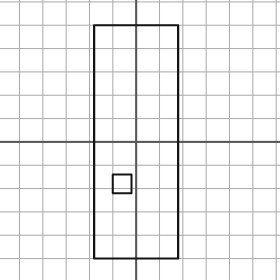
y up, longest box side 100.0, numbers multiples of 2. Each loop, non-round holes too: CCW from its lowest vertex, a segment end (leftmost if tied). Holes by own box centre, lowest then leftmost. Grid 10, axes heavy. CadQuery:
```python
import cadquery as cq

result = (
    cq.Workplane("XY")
    .moveTo(-18.0, -50.0)
    .lineTo(18.0, -50.0)
    .lineTo(18.0, 50.0)
    .lineTo(-18.0, 50.0)
    .close()
    .moveTo(-10.0, -22.0)
    .lineTo(-2.0, -22.0)
    .lineTo(-2.0, -14.0)
    .lineTo(-10.0, -14.0)
    .close()
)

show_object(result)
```